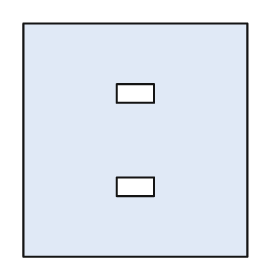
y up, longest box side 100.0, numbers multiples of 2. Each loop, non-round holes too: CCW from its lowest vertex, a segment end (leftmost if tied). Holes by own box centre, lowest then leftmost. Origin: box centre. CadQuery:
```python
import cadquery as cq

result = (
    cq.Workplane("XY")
    .moveTo(-48.0, -50.0)
    .lineTo(48.0, -50.0)
    .lineTo(48.0, 50.0)
    .lineTo(-48.0, 50.0)
    .close()
    .moveTo(-8.0, -24.0)
    .lineTo(8.0, -24.0)
    .lineTo(8.0, -16.0)
    .lineTo(-8.0, -16.0)
    .close()
    .moveTo(-8.0, 16.0)
    .lineTo(8.0, 16.0)
    .lineTo(8.0, 24.0)
    .lineTo(-8.0, 24.0)
    .close()
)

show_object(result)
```